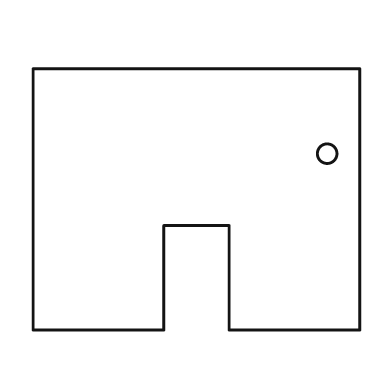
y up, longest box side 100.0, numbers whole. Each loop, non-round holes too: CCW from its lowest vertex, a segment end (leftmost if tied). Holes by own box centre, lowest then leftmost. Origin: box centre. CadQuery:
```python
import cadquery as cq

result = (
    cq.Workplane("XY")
    .moveTo(-50.0, -40.0)
    .lineTo(-10.0, -40.0)
    .lineTo(-10.0, -8.0)
    .lineTo(10.0, -8.0)
    .lineTo(10.0, -40.0)
    .lineTo(50.0, -40.0)
    .lineTo(50.0, 40.0)
    .lineTo(-50.0, 40.0)
    .close()
    .moveTo(40.0, 14.0)
    .circle(3.0)
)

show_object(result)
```